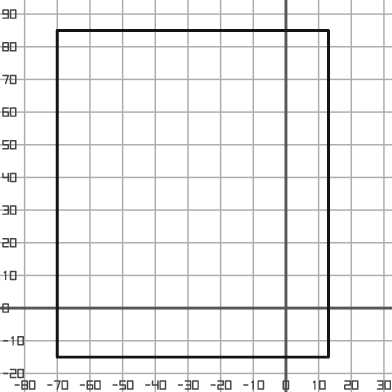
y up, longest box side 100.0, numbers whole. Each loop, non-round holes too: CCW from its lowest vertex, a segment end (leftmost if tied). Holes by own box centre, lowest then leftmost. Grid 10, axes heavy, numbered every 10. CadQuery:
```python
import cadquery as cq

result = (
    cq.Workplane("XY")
    .moveTo(-70.0, -15.0)
    .lineTo(13.0, -15.0)
    .lineTo(13.0, 85.0)
    .lineTo(-70.0, 85.0)
    .close()
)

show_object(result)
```